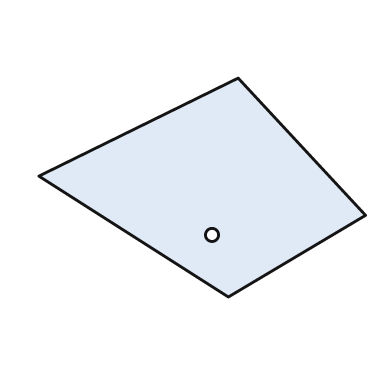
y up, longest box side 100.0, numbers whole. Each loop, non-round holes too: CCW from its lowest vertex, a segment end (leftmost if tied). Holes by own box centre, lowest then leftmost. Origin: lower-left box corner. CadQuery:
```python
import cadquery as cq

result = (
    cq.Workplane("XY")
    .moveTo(58.0, 0.0)
    .lineTo(100.0, 25.0)
    .lineTo(61.0, 67.0)
    .lineTo(0.0, 37.0)
    .close()
    .moveTo(53.0, 19.0)
    .circle(2.0)
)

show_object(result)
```